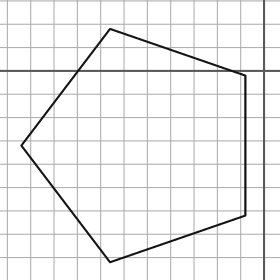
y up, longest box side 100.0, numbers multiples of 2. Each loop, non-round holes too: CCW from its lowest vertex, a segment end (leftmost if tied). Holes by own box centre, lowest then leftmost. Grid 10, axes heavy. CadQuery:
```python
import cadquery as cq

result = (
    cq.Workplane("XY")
    .moveTo(-66.0, -82.0)
    .lineTo(-8.0, -62.0)
    .lineTo(-8.0, -2.0)
    .lineTo(-66.0, 18.0)
    .lineTo(-104.0, -32.0)
    .close()
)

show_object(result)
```